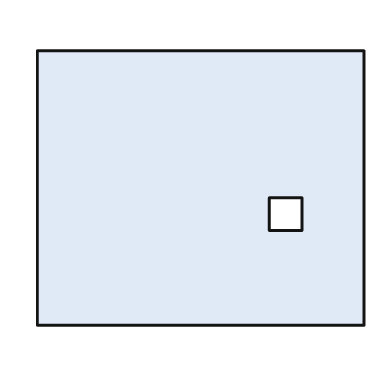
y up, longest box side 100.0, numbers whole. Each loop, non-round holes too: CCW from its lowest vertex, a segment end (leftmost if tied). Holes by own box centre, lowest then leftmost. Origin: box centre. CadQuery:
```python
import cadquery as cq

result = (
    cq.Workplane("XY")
    .moveTo(-50.0, -42.0)
    .lineTo(50.0, -42.0)
    .lineTo(50.0, 42.0)
    .lineTo(-50.0, 42.0)
    .close()
    .moveTo(21.0, -13.0)
    .lineTo(31.0, -13.0)
    .lineTo(31.0, -3.0)
    .lineTo(21.0, -3.0)
    .close()
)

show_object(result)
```